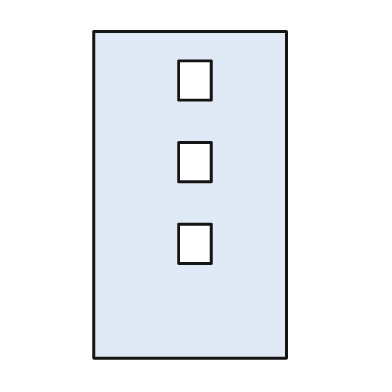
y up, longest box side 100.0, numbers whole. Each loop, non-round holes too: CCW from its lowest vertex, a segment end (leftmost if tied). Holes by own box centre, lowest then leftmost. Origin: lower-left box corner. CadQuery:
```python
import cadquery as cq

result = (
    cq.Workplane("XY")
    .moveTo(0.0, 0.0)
    .lineTo(59.0, 0.0)
    .lineTo(59.0, 100.0)
    .lineTo(0.0, 100.0)
    .close()
    .moveTo(26.0, 29.0)
    .lineTo(36.0, 29.0)
    .lineTo(36.0, 41.0)
    .lineTo(26.0, 41.0)
    .close()
    .moveTo(26.0, 54.0)
    .lineTo(36.0, 54.0)
    .lineTo(36.0, 66.0)
    .lineTo(26.0, 66.0)
    .close()
    .moveTo(26.0, 79.0)
    .lineTo(36.0, 79.0)
    .lineTo(36.0, 91.0)
    .lineTo(26.0, 91.0)
    .close()
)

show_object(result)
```